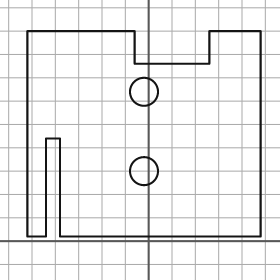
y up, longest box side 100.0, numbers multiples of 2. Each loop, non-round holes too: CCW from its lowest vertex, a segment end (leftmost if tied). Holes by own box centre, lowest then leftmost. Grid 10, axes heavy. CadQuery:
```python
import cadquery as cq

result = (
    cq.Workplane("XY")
    .moveTo(-52.0, 2.0)
    .lineTo(-44.0, 2.0)
    .lineTo(-44.0, 44.0)
    .lineTo(-38.0, 44.0)
    .lineTo(-38.0, 2.0)
    .lineTo(48.0, 2.0)
    .lineTo(48.0, 90.0)
    .lineTo(26.0, 90.0)
    .lineTo(26.0, 76.0)
    .lineTo(-6.0, 76.0)
    .lineTo(-6.0, 90.0)
    .lineTo(-52.0, 90.0)
    .close()
    .moveTo(-2.0, 30.0)
    .circle(6.0)
    .moveTo(-2.0, 64.0)
    .circle(6.0)
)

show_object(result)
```